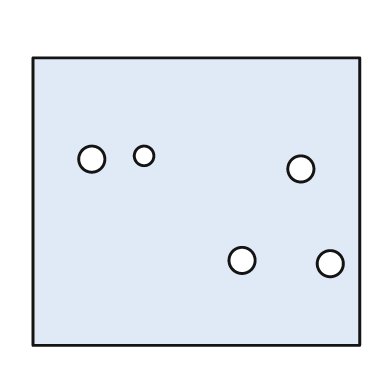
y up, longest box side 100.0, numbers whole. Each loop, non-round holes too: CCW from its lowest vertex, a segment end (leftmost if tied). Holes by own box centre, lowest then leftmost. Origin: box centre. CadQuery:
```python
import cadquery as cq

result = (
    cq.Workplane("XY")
    .moveTo(-50.0, -44.0)
    .lineTo(50.0, -44.0)
    .lineTo(50.0, 44.0)
    .lineTo(-50.0, 44.0)
    .close()
    .moveTo(41.0, -19.0)
    .circle(4.0)
    .moveTo(14.0, -18.0)
    .circle(4.0)
    .moveTo(32.0, 10.0)
    .circle(4.0)
    .moveTo(-32.0, 13.0)
    .circle(4.0)
    .moveTo(-16.0, 14.0)
    .circle(3.0)
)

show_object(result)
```